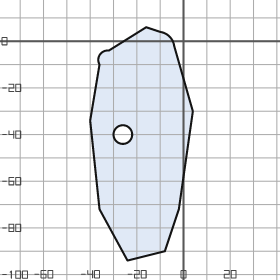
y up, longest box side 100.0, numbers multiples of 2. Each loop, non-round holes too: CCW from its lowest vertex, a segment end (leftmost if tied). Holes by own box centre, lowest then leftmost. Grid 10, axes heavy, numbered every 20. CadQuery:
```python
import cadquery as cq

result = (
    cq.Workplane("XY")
    .moveTo(-24.0, -94.0)
    .lineTo(-8.0, -90.0)
    .lineTo(-2.0, -72.0)
    .lineTo(4.0, -30.0)
    .lineTo(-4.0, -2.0)
    .threePointArc((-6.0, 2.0), (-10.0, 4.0))
    .lineTo(-16.0, 6.0)
    .lineTo(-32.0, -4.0)
    .threePointArc((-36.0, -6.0), (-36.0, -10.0))
    .lineTo(-40.0, -34.0)
    .lineTo(-36.0, -72.0)
    .close()
    .moveTo(-26.0, -40.0)
    .circle(4.0)
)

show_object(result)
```